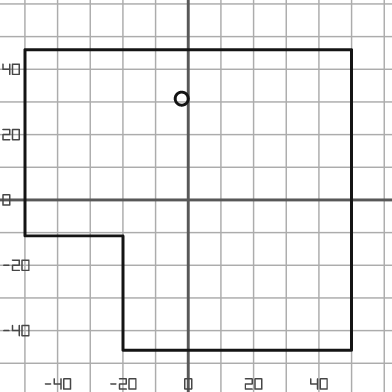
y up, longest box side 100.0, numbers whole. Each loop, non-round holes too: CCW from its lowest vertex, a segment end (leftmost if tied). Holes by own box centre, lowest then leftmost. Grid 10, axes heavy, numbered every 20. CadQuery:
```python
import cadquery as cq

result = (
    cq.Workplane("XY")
    .moveTo(-20.0, -46.0)
    .lineTo(50.0, -46.0)
    .lineTo(50.0, 46.0)
    .lineTo(-50.0, 46.0)
    .lineTo(-50.0, -11.0)
    .lineTo(-20.0, -11.0)
    .close()
    .moveTo(-2.0, 31.0)
    .circle(2.0)
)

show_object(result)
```